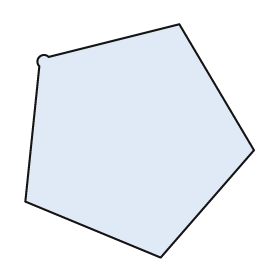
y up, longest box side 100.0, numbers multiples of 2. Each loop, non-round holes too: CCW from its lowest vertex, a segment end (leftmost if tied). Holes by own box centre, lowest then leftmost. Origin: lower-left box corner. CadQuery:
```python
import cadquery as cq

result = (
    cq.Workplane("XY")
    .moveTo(58.0, 0.0)
    .lineTo(98.0, 46.0)
    .lineTo(66.0, 100.0)
    .lineTo(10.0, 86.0)
    .threePointArc((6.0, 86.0), (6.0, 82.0))
    .lineTo(0.0, 24.0)
    .close()
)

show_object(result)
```